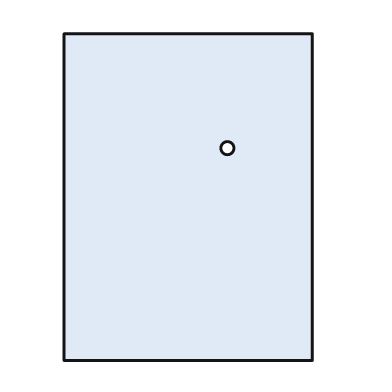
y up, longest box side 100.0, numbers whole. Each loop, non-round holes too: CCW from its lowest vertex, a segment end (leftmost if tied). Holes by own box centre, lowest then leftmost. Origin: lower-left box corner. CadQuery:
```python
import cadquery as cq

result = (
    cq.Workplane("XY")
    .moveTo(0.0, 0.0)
    .lineTo(76.0, 0.0)
    .lineTo(76.0, 100.0)
    .lineTo(0.0, 100.0)
    .close()
    .moveTo(50.0, 65.0)
    .circle(2.0)
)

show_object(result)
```